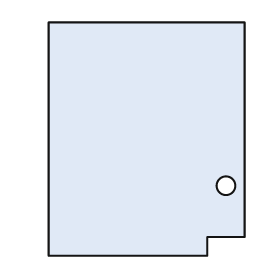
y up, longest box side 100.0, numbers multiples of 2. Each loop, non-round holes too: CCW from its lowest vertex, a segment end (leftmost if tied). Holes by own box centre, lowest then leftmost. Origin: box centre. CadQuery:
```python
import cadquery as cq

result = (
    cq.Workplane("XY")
    .moveTo(-42.0, -50.0)
    .lineTo(26.0, -50.0)
    .lineTo(26.0, -42.0)
    .lineTo(42.0, -42.0)
    .lineTo(42.0, 50.0)
    .lineTo(-42.0, 50.0)
    .close()
    .moveTo(34.0, -20.0)
    .circle(4.0)
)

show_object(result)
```